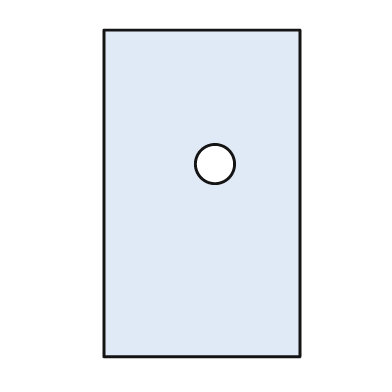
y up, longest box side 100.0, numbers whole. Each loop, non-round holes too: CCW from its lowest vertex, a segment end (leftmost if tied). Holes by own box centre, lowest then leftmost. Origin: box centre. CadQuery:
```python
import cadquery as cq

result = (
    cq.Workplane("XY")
    .moveTo(-30.0, -50.0)
    .lineTo(30.0, -50.0)
    .lineTo(30.0, 50.0)
    .lineTo(-30.0, 50.0)
    .close()
    .moveTo(4.0, 9.0)
    .circle(6.0)
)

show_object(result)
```